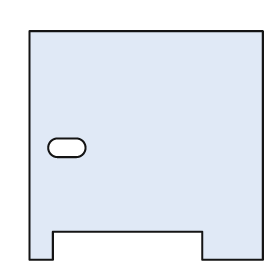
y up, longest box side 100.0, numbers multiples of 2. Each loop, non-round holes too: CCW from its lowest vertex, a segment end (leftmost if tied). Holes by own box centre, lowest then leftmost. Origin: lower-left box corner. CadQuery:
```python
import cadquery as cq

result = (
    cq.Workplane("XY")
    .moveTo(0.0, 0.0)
    .lineTo(10.0, 0.0)
    .lineTo(10.0, 12.0)
    .lineTo(74.0, 12.0)
    .lineTo(74.0, 0.0)
    .lineTo(100.0, 0.0)
    .lineTo(100.0, 98.0)
    .lineTo(0.0, 98.0)
    .close()
    .moveTo(12.0, 44.0)
    .lineTo(20.0, 44.0)
    .threePointArc((24.0, 48.0), (20.0, 52.0))
    .lineTo(12.0, 52.0)
    .threePointArc((8.0, 48.0), (12.0, 44.0))
    .close()
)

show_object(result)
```